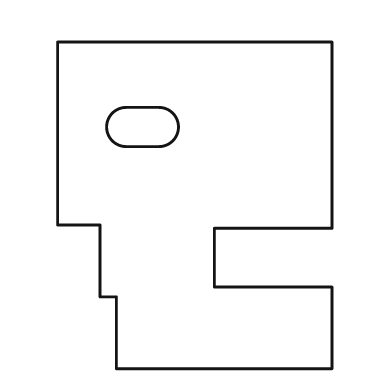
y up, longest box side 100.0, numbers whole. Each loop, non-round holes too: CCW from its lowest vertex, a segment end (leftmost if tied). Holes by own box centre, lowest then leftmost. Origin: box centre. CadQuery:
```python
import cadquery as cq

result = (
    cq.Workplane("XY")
    .moveTo(-24.0, -50.0)
    .lineTo(42.0, -50.0)
    .lineTo(42.0, -25.0)
    .lineTo(6.0, -25.0)
    .lineTo(6.0, -7.0)
    .lineTo(42.0, -7.0)
    .lineTo(42.0, 50.0)
    .lineTo(-42.0, 50.0)
    .lineTo(-42.0, -6.0)
    .lineTo(-29.0, -6.0)
    .lineTo(-29.0, -28.0)
    .lineTo(-24.0, -28.0)
    .close()
    .moveTo(-21.0, 18.0)
    .lineTo(-11.0, 18.0)
    .threePointArc((-5.0, 24.0), (-11.0, 30.0))
    .lineTo(-21.0, 30.0)
    .threePointArc((-27.0, 24.0), (-21.0, 18.0))
    .close()
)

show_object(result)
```